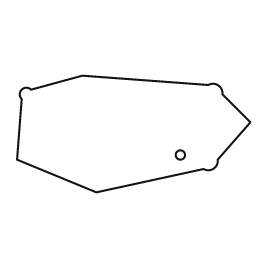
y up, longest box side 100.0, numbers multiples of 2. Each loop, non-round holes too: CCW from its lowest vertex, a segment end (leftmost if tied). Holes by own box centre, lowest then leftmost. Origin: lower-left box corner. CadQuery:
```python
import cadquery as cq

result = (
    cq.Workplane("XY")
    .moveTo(34.0, 0.0)
    .lineTo(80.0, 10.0)
    .threePointArc((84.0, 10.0), (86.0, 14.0))
    .lineTo(100.0, 30.0)
    .lineTo(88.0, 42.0)
    .threePointArc((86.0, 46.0), (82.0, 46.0))
    .lineTo(28.0, 50.0)
    .lineTo(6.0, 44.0)
    .threePointArc((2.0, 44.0), (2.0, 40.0))
    .lineTo(0.0, 14.0)
    .close()
    .moveTo(70.0, 16.0)
    .circle(2.0)
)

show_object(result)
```